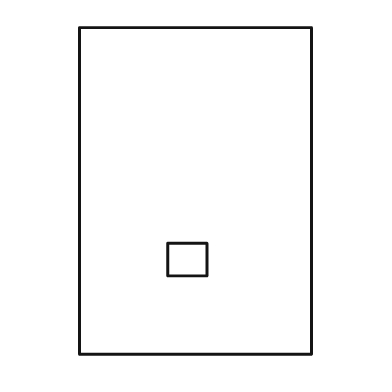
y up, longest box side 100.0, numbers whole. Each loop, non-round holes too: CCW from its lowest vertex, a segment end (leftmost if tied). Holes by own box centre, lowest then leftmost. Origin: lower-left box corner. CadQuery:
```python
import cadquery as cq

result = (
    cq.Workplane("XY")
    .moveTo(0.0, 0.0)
    .lineTo(71.0, 0.0)
    .lineTo(71.0, 100.0)
    .lineTo(0.0, 100.0)
    .close()
    .moveTo(27.0, 24.0)
    .lineTo(39.0, 24.0)
    .lineTo(39.0, 34.0)
    .lineTo(27.0, 34.0)
    .close()
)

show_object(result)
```